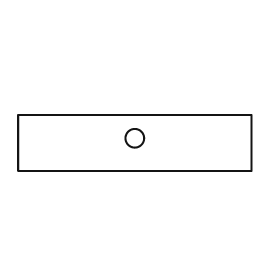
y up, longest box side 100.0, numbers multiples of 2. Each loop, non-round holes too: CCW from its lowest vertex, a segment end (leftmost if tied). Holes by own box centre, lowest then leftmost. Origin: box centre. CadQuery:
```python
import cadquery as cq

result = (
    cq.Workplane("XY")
    .moveTo(-50.0, -12.0)
    .lineTo(50.0, -12.0)
    .lineTo(50.0, 12.0)
    .lineTo(-50.0, 12.0)
    .close()
    .moveTo(0.0, 2.0)
    .circle(4.0)
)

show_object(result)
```